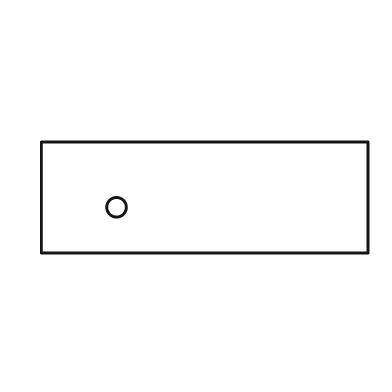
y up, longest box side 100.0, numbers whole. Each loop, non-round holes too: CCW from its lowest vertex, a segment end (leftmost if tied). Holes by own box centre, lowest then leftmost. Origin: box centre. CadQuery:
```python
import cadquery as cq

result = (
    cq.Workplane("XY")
    .moveTo(-50.0, -17.0)
    .lineTo(50.0, -17.0)
    .lineTo(50.0, 17.0)
    .lineTo(-50.0, 17.0)
    .close()
    .moveTo(-27.0, -3.0)
    .circle(3.0)
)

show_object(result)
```